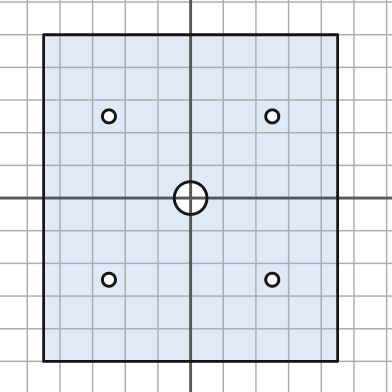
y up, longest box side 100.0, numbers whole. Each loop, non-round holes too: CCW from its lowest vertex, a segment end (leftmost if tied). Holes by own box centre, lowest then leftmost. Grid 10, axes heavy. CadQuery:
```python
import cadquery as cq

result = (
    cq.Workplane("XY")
    .moveTo(-45.0, -50.0)
    .lineTo(45.0, -50.0)
    .lineTo(45.0, 50.0)
    .lineTo(-45.0, 50.0)
    .close()
    .moveTo(-25.0, -25.0)
    .circle(2.0)
    .moveTo(25.0, -25.0)
    .circle(2.0)
    .moveTo(0.0, 0.0)
    .circle(5.0)
    .moveTo(-25.0, 25.0)
    .circle(2.0)
    .moveTo(25.0, 25.0)
    .circle(2.0)
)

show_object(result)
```